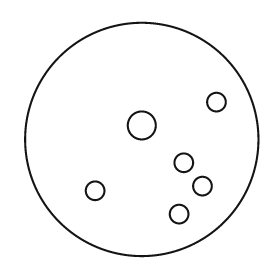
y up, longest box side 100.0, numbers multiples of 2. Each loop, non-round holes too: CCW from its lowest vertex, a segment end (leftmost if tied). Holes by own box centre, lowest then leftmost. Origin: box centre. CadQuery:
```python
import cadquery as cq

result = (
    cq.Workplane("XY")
    .moveTo(0.0, 0.0)
    .circle(50.0)
    .moveTo(16.0, -32.0)
    .circle(4.0)
    .moveTo(-20.0, -22.0)
    .circle(4.0)
    .moveTo(26.0, -20.0)
    .circle(4.0)
    .moveTo(18.0, -10.0)
    .circle(4.0)
    .moveTo(0.0, 6.0)
    .circle(6.0)
    .moveTo(32.0, 16.0)
    .circle(4.0)
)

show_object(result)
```